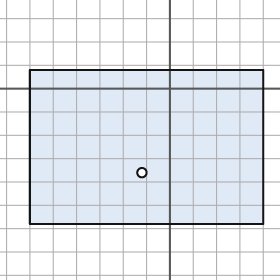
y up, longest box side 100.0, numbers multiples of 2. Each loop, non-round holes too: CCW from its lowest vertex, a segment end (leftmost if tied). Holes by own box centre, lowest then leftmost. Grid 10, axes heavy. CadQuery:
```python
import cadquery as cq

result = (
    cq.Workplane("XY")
    .moveTo(-60.0, -58.0)
    .lineTo(40.0, -58.0)
    .lineTo(40.0, 8.0)
    .lineTo(-60.0, 8.0)
    .close()
    .moveTo(-12.0, -36.0)
    .circle(2.0)
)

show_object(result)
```